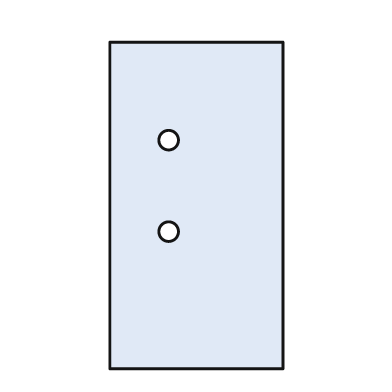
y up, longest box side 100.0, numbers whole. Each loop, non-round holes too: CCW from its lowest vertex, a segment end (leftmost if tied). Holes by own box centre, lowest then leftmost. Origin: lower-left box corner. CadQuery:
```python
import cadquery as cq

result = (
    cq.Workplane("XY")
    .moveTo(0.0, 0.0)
    .lineTo(53.0, 0.0)
    .lineTo(53.0, 100.0)
    .lineTo(0.0, 100.0)
    .close()
    .moveTo(18.0, 42.0)
    .circle(3.0)
    .moveTo(18.0, 70.0)
    .circle(3.0)
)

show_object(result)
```